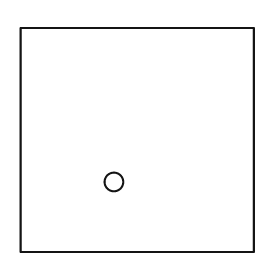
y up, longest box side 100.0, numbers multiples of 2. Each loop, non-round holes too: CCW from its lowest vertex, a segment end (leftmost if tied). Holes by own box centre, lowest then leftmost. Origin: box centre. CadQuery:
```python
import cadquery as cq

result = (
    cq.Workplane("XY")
    .moveTo(-50.0, -48.0)
    .lineTo(50.0, -48.0)
    .lineTo(50.0, 48.0)
    .lineTo(-50.0, 48.0)
    .close()
    .moveTo(-10.0, -18.0)
    .circle(4.0)
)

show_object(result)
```